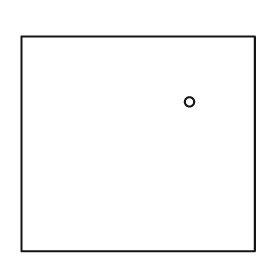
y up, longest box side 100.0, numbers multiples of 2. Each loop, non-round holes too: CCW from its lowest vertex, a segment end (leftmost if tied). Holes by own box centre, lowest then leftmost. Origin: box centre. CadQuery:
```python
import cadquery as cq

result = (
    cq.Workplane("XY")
    .moveTo(-50.0, -46.0)
    .lineTo(50.0, -46.0)
    .lineTo(50.0, 46.0)
    .lineTo(-50.0, 46.0)
    .close()
    .moveTo(22.0, 18.0)
    .circle(2.0)
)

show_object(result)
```